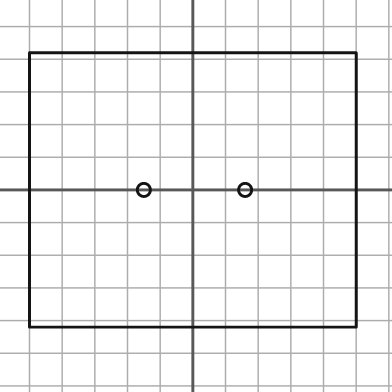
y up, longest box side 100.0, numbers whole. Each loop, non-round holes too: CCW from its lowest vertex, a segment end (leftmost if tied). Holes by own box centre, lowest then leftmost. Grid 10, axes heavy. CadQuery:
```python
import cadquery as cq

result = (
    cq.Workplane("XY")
    .moveTo(-50.0, -42.0)
    .lineTo(50.0, -42.0)
    .lineTo(50.0, 42.0)
    .lineTo(-50.0, 42.0)
    .close()
    .moveTo(-15.0, 0.0)
    .circle(2.0)
    .moveTo(16.0, 0.0)
    .circle(2.0)
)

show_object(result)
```